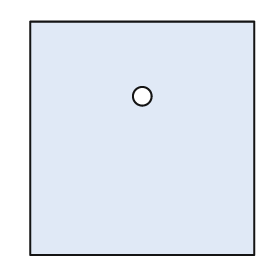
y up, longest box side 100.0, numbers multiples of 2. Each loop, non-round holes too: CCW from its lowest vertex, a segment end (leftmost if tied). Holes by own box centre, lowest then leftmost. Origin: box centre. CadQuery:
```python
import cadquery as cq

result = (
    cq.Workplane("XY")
    .moveTo(-48.0, -50.0)
    .lineTo(48.0, -50.0)
    .lineTo(48.0, 50.0)
    .lineTo(-48.0, 50.0)
    .close()
    .moveTo(0.0, 18.0)
    .circle(4.0)
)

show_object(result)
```